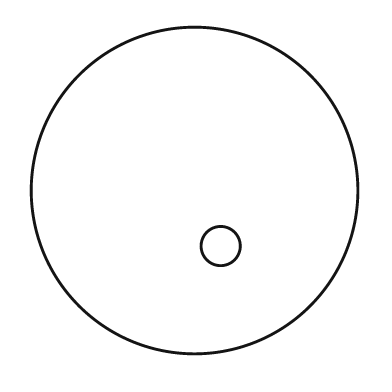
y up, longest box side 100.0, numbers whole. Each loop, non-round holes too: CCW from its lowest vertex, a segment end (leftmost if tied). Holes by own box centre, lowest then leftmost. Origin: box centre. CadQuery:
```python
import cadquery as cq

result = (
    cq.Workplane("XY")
    .moveTo(0.0, 0.0)
    .circle(50.0)
    .moveTo(8.0, -17.0)
    .circle(6.0)
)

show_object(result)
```